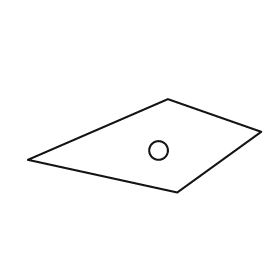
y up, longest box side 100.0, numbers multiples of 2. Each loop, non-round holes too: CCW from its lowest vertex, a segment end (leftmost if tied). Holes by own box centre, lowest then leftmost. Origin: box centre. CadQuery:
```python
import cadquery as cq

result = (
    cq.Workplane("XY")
    .moveTo(14.0, -20.0)
    .lineTo(50.0, 6.0)
    .lineTo(10.0, 20.0)
    .lineTo(-50.0, -6.0)
    .close()
    .moveTo(6.0, -2.0)
    .circle(4.0)
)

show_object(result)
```